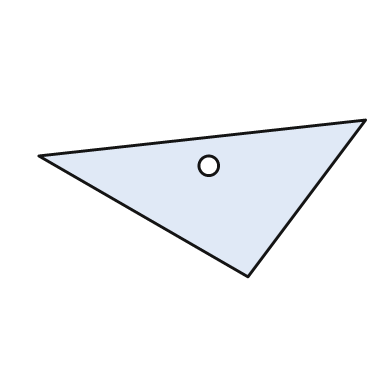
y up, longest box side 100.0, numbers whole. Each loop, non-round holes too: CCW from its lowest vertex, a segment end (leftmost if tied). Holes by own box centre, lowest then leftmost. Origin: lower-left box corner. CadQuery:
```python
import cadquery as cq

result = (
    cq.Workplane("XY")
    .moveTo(64.0, 0.0)
    .lineTo(100.0, 48.0)
    .lineTo(0.0, 37.0)
    .close()
    .moveTo(52.0, 34.0)
    .circle(3.0)
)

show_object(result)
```